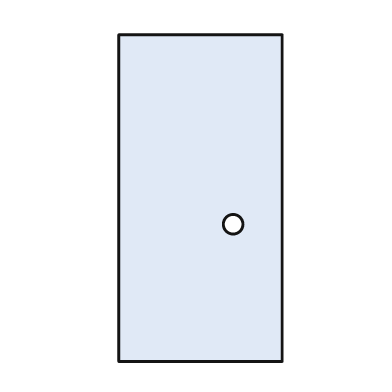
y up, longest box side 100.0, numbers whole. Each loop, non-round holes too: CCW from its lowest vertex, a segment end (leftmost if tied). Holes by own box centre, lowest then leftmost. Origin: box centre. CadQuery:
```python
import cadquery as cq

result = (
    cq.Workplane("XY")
    .moveTo(-25.0, -50.0)
    .lineTo(25.0, -50.0)
    .lineTo(25.0, 50.0)
    .lineTo(-25.0, 50.0)
    .close()
    .moveTo(10.0, -8.0)
    .circle(3.0)
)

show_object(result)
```